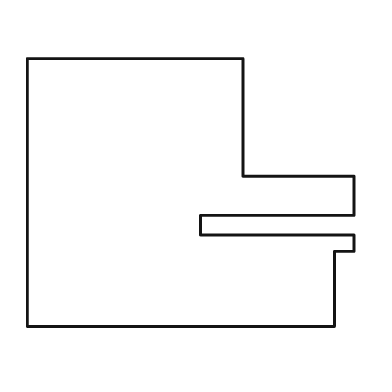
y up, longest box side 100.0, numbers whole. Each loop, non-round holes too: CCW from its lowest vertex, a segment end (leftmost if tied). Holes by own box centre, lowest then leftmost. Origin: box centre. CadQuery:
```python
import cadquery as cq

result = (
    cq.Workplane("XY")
    .moveTo(-50.0, -41.0)
    .lineTo(44.0, -41.0)
    .lineTo(44.0, -18.0)
    .lineTo(50.0, -18.0)
    .lineTo(50.0, -13.0)
    .lineTo(3.0, -13.0)
    .lineTo(3.0, -7.0)
    .lineTo(50.0, -7.0)
    .lineTo(50.0, 5.0)
    .lineTo(16.0, 5.0)
    .lineTo(16.0, 41.0)
    .lineTo(-50.0, 41.0)
    .close()
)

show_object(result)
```